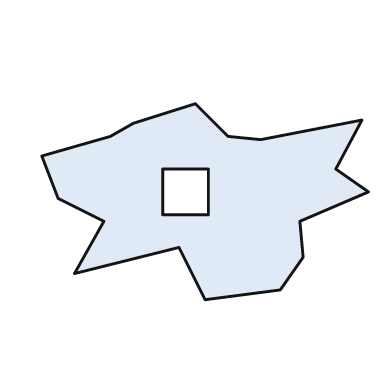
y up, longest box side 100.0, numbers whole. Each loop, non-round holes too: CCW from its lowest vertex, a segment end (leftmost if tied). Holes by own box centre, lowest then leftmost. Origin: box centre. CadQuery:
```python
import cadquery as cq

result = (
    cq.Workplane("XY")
    .moveTo(0.0, -30.0)
    .lineTo(23.0, -27.0)
    .lineTo(30.0, -17.0)
    .lineTo(29.0, -6.0)
    .lineTo(50.0, 3.0)
    .lineTo(40.0, 10.0)
    .lineTo(48.0, 25.0)
    .lineTo(17.0, 19.0)
    .lineTo(7.0, 20.0)
    .lineTo(-3.0, 30.0)
    .lineTo(-22.0, 24.0)
    .lineTo(-29.0, 20.0)
    .lineTo(-50.0, 14.0)
    .lineTo(-45.0, 1.0)
    .lineTo(-31.0, -6.0)
    .lineTo(-40.0, -22.0)
    .lineTo(-8.0, -14.0)
    .close()
    .moveTo(-13.0, -4.0)
    .lineTo(1.0, -4.0)
    .lineTo(1.0, 10.0)
    .lineTo(-13.0, 10.0)
    .close()
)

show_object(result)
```